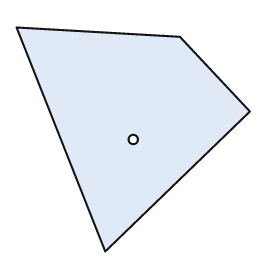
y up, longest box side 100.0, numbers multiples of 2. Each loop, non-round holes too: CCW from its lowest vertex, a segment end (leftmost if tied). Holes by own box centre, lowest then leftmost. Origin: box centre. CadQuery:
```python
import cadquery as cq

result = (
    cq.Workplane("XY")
    .moveTo(-12.0, -48.0)
    .lineTo(50.0, 12.0)
    .lineTo(20.0, 44.0)
    .lineTo(-50.0, 48.0)
    .close()
    .moveTo(0.0, 0.0)
    .circle(2.0)
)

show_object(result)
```